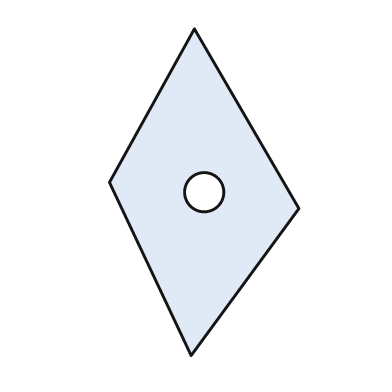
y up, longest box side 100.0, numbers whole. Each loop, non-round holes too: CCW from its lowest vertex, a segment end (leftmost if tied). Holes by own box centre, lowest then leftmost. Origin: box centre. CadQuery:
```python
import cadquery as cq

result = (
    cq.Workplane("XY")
    .moveTo(-4.0, -50.0)
    .lineTo(29.0, -5.0)
    .lineTo(-3.0, 50.0)
    .lineTo(-29.0, 3.0)
    .close()
    .moveTo(0.0, 0.0)
    .circle(6.0)
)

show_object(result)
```